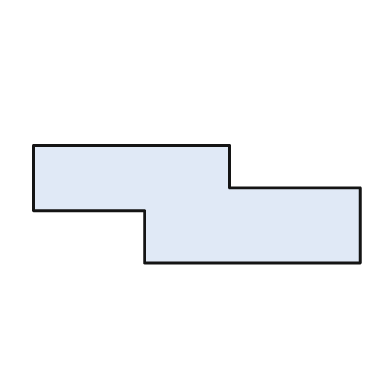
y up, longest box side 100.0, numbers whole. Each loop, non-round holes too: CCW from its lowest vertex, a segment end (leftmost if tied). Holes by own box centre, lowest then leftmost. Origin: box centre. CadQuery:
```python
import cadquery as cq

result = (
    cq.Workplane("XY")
    .moveTo(-16.0, -18.0)
    .lineTo(50.0, -18.0)
    .lineTo(50.0, 5.0)
    .lineTo(10.0, 5.0)
    .lineTo(10.0, 18.0)
    .lineTo(-50.0, 18.0)
    .lineTo(-50.0, -2.0)
    .lineTo(-16.0, -2.0)
    .close()
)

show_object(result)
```